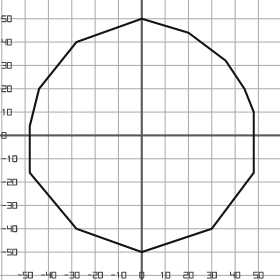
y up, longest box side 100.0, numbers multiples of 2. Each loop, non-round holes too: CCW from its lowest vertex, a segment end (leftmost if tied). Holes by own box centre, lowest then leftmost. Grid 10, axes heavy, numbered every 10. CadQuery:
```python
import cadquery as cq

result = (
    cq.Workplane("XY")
    .moveTo(0.0, -50.0)
    .lineTo(30.0, -40.0)
    .lineTo(48.0, -16.0)
    .lineTo(48.0, 10.0)
    .lineTo(44.0, 20.0)
    .lineTo(36.0, 32.0)
    .lineTo(20.0, 44.0)
    .lineTo(0.0, 50.0)
    .lineTo(-28.0, 40.0)
    .lineTo(-44.0, 20.0)
    .lineTo(-48.0, 4.0)
    .lineTo(-48.0, -16.0)
    .lineTo(-28.0, -40.0)
    .close()
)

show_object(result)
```